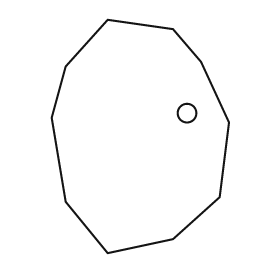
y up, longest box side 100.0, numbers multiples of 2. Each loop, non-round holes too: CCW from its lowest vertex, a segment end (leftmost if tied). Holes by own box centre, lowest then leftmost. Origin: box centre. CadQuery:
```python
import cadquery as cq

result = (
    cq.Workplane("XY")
    .moveTo(-14.0, -50.0)
    .lineTo(14.0, -44.0)
    .lineTo(34.0, -26.0)
    .lineTo(38.0, 6.0)
    .lineTo(26.0, 32.0)
    .lineTo(14.0, 46.0)
    .lineTo(-14.0, 50.0)
    .lineTo(-32.0, 30.0)
    .lineTo(-38.0, 8.0)
    .lineTo(-32.0, -28.0)
    .close()
    .moveTo(20.0, 10.0)
    .circle(4.0)
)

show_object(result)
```